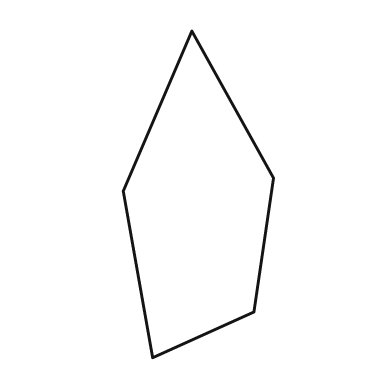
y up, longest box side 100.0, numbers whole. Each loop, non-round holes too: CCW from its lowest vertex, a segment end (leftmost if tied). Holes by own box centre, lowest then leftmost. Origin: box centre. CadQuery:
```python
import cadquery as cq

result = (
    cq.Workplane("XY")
    .moveTo(-14.0, -50.0)
    .lineTo(17.0, -36.0)
    .lineTo(23.0, 5.0)
    .lineTo(-2.0, 50.0)
    .lineTo(-23.0, 1.0)
    .close()
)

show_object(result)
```